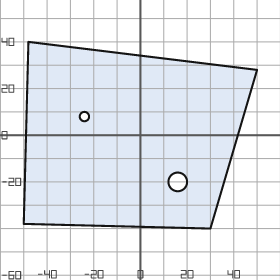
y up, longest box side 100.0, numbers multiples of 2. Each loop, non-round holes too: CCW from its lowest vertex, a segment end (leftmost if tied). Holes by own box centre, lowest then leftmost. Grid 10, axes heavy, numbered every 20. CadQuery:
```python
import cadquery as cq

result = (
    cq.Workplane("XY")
    .moveTo(30.0, -40.0)
    .lineTo(50.0, 28.0)
    .lineTo(-48.0, 40.0)
    .lineTo(-50.0, -38.0)
    .close()
    .moveTo(16.0, -20.0)
    .circle(4.0)
    .moveTo(-24.0, 8.0)
    .circle(2.0)
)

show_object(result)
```